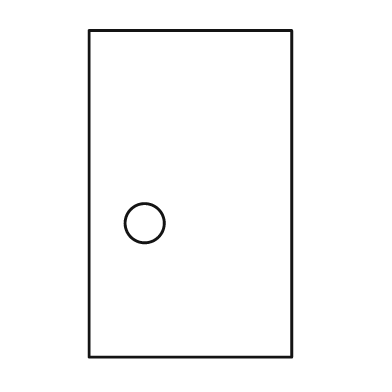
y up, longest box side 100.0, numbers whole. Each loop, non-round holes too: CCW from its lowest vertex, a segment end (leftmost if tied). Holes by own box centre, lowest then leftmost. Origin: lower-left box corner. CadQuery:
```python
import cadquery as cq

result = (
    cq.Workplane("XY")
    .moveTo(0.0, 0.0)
    .lineTo(62.0, 0.0)
    .lineTo(62.0, 100.0)
    .lineTo(0.0, 100.0)
    .close()
    .moveTo(17.0, 41.0)
    .circle(6.0)
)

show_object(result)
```